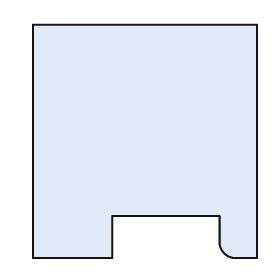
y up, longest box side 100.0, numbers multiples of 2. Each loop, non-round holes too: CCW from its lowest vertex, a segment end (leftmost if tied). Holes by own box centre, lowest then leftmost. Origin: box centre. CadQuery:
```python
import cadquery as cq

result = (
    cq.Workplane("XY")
    .moveTo(-48.0, -50.0)
    .lineTo(-14.0, -50.0)
    .lineTo(-14.0, -32.0)
    .lineTo(32.0, -32.0)
    .lineTo(32.0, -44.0)
    .threePointArc((34.0, -48.0), (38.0, -50.0))
    .lineTo(48.0, -50.0)
    .lineTo(48.0, 50.0)
    .lineTo(-48.0, 50.0)
    .close()
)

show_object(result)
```